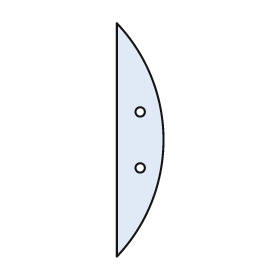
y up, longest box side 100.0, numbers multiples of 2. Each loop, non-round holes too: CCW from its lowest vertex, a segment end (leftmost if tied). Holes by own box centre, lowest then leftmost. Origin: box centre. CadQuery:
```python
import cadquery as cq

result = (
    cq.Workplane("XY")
    .moveTo(-10.0, -50.0)
    .threePointArc((10.0, 0.0), (-10.0, 50.0))
    .close()
    .moveTo(0.0, -12.0)
    .circle(2.0)
    .moveTo(0.0, 12.0)
    .circle(2.0)
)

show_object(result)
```